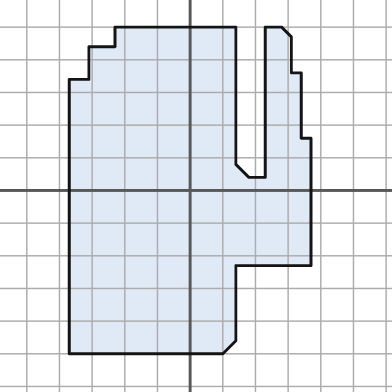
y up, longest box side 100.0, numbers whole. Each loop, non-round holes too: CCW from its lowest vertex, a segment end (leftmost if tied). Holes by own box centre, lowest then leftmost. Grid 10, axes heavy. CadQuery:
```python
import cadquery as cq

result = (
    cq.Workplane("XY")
    .moveTo(-37.0, -50.0)
    .lineTo(10.0, -50.0)
    .lineTo(14.0, -46.0)
    .lineTo(14.0, -23.0)
    .lineTo(37.0, -23.0)
    .lineTo(37.0, 16.0)
    .lineTo(34.0, 16.0)
    .lineTo(34.0, 36.0)
    .lineTo(31.0, 36.0)
    .lineTo(31.0, 47.0)
    .lineTo(28.0, 50.0)
    .lineTo(23.0, 50.0)
    .lineTo(23.0, 4.0)
    .lineTo(18.0, 4.0)
    .lineTo(14.0, 8.0)
    .lineTo(14.0, 50.0)
    .lineTo(-23.0, 50.0)
    .lineTo(-23.0, 44.0)
    .lineTo(-31.0, 44.0)
    .lineTo(-31.0, 34.0)
    .lineTo(-37.0, 34.0)
    .close()
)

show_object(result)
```